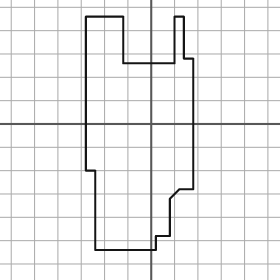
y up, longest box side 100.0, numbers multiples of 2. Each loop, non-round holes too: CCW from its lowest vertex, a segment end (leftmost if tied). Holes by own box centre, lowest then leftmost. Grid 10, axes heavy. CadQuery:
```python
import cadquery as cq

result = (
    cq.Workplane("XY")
    .moveTo(-24.0, -54.0)
    .lineTo(2.0, -54.0)
    .lineTo(2.0, -48.0)
    .lineTo(8.0, -48.0)
    .lineTo(8.0, -32.0)
    .lineTo(12.0, -28.0)
    .lineTo(18.0, -28.0)
    .lineTo(18.0, 28.0)
    .lineTo(14.0, 28.0)
    .lineTo(14.0, 46.0)
    .lineTo(10.0, 46.0)
    .lineTo(10.0, 26.0)
    .lineTo(-12.0, 26.0)
    .lineTo(-12.0, 46.0)
    .lineTo(-28.0, 46.0)
    .lineTo(-28.0, -20.0)
    .lineTo(-24.0, -20.0)
    .close()
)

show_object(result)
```